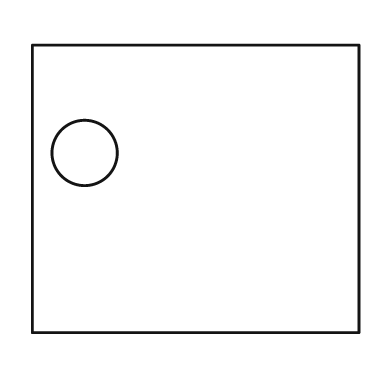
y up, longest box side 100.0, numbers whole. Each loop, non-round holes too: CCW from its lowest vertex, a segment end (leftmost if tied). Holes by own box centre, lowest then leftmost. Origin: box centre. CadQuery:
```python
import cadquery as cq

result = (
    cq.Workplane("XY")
    .moveTo(-50.0, -44.0)
    .lineTo(50.0, -44.0)
    .lineTo(50.0, 44.0)
    .lineTo(-50.0, 44.0)
    .close()
    .moveTo(-34.0, 11.0)
    .circle(10.0)
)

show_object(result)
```